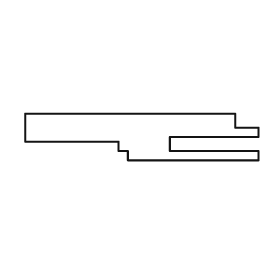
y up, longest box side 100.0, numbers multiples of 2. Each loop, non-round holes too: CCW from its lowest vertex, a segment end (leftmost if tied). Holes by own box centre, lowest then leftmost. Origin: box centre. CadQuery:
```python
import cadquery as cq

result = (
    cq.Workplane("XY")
    .moveTo(-6.0, -10.0)
    .lineTo(50.0, -10.0)
    .lineTo(50.0, -6.0)
    .lineTo(12.0, -6.0)
    .lineTo(12.0, 0.0)
    .lineTo(50.0, 0.0)
    .lineTo(50.0, 4.0)
    .lineTo(40.0, 4.0)
    .lineTo(40.0, 10.0)
    .lineTo(-50.0, 10.0)
    .lineTo(-50.0, -2.0)
    .lineTo(-10.0, -2.0)
    .lineTo(-10.0, -6.0)
    .lineTo(-6.0, -6.0)
    .close()
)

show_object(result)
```